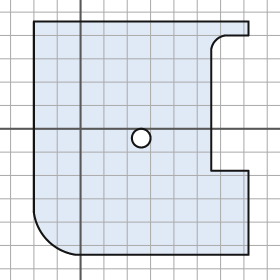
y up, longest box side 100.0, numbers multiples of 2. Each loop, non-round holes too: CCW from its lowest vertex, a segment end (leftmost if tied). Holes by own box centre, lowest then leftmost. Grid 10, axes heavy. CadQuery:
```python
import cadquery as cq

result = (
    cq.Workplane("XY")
    .moveTo(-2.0, -54.0)
    .lineTo(72.0, -54.0)
    .lineTo(72.0, -18.0)
    .lineTo(56.0, -18.0)
    .lineTo(56.0, 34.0)
    .threePointArc((58.0, 38.0), (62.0, 40.0))
    .lineTo(72.0, 40.0)
    .lineTo(72.0, 46.0)
    .lineTo(-20.0, 46.0)
    .lineTo(-20.0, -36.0)
    .threePointArc((-14.0, -48.0), (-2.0, -54.0))
    .close()
    .moveTo(26.0, -4.0)
    .circle(4.0)
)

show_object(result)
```